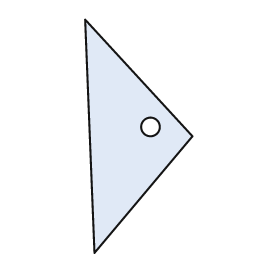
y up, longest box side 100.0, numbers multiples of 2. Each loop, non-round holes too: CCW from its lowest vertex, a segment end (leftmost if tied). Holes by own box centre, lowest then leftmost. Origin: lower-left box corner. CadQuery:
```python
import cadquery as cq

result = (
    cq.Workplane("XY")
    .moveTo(4.0, 0.0)
    .lineTo(46.0, 50.0)
    .lineTo(0.0, 100.0)
    .close()
    .moveTo(28.0, 54.0)
    .circle(4.0)
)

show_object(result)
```